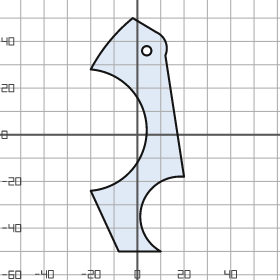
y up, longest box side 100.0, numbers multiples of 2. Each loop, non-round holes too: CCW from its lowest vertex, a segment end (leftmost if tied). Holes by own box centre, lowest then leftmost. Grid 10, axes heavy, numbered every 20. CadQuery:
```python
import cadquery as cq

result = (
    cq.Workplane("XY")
    .moveTo(-8.0, -50.0)
    .lineTo(10.0, -50.0)
    .threePointArc((2.0, -30.0), (20.0, -18.0))
    .lineTo(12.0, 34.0)
    .threePointArc((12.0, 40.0), (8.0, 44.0))
    .lineTo(-2.0, 50.0)
    .threePointArc((-12.0, 40.0), (-20.0, 28.0))
    .threePointArc((4.0, 2.0), (-20.0, -24.0))
    .close()
    .moveTo(4.0, 36.0)
    .circle(2.0)
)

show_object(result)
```